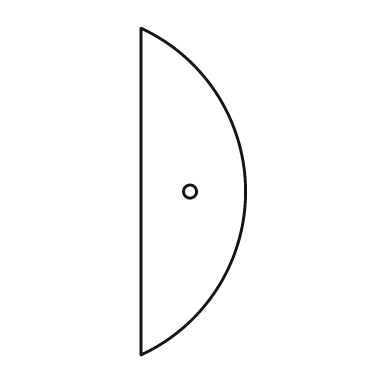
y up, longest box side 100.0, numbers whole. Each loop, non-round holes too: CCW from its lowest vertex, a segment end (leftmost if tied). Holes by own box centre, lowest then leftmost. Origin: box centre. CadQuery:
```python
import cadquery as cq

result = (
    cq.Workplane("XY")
    .moveTo(-16.0, -50.0)
    .threePointArc((16.0, 0.0), (-16.0, 50.0))
    .close()
    .moveTo(-1.0, 0.0)
    .circle(2.0)
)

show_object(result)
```